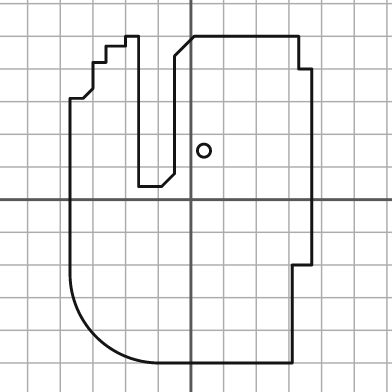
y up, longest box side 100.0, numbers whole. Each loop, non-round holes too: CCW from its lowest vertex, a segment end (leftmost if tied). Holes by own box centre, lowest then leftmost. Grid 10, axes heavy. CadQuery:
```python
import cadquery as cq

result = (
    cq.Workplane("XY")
    .moveTo(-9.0, -50.0)
    .lineTo(31.0, -50.0)
    .lineTo(31.0, -20.0)
    .lineTo(37.0, -20.0)
    .lineTo(37.0, 40.0)
    .lineTo(33.0, 40.0)
    .lineTo(33.0, 50.0)
    .lineTo(1.0, 50.0)
    .lineTo(-5.0, 44.0)
    .lineTo(-5.0, 8.0)
    .lineTo(-9.0, 4.0)
    .lineTo(-16.0, 4.0)
    .lineTo(-16.0, 50.0)
    .lineTo(-20.0, 50.0)
    .lineTo(-20.0, 47.0)
    .lineTo(-26.0, 47.0)
    .lineTo(-26.0, 42.0)
    .lineTo(-30.0, 42.0)
    .lineTo(-30.0, 34.0)
    .lineTo(-33.0, 31.0)
    .lineTo(-37.0, 31.0)
    .lineTo(-37.0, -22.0)
    .threePointArc((-29.0, -42.0), (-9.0, -50.0))
    .close()
    .moveTo(4.0, 15.0)
    .circle(2.0)
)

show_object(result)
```